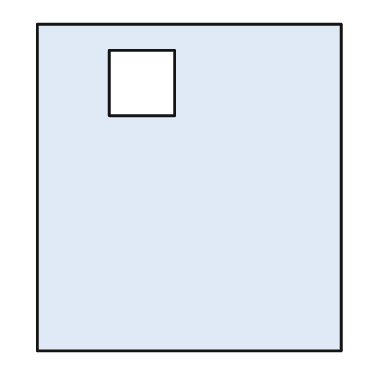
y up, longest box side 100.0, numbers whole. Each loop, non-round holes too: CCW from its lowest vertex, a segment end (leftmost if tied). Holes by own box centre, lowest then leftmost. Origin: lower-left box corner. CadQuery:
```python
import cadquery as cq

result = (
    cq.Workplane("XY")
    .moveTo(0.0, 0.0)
    .lineTo(93.0, 0.0)
    .lineTo(93.0, 100.0)
    .lineTo(0.0, 100.0)
    .close()
    .moveTo(22.0, 72.0)
    .lineTo(42.0, 72.0)
    .lineTo(42.0, 92.0)
    .lineTo(22.0, 92.0)
    .close()
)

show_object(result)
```